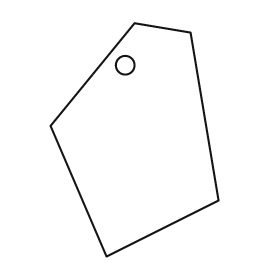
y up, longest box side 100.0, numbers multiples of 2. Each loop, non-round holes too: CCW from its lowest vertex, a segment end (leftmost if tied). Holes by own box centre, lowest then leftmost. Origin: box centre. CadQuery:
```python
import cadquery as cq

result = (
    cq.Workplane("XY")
    .moveTo(-12.0, -50.0)
    .lineTo(36.0, -26.0)
    .lineTo(24.0, 46.0)
    .lineTo(0.0, 50.0)
    .lineTo(-36.0, 6.0)
    .close()
    .moveTo(-4.0, 32.0)
    .circle(4.0)
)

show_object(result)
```